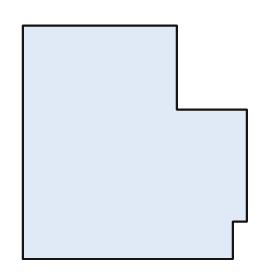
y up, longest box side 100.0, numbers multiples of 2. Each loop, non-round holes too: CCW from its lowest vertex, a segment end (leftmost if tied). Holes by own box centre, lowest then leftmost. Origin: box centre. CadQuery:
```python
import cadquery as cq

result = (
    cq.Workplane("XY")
    .moveTo(-48.0, -50.0)
    .lineTo(42.0, -50.0)
    .lineTo(42.0, -34.0)
    .lineTo(48.0, -34.0)
    .lineTo(48.0, 14.0)
    .lineTo(18.0, 14.0)
    .lineTo(18.0, 50.0)
    .lineTo(-48.0, 50.0)
    .close()
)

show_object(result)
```